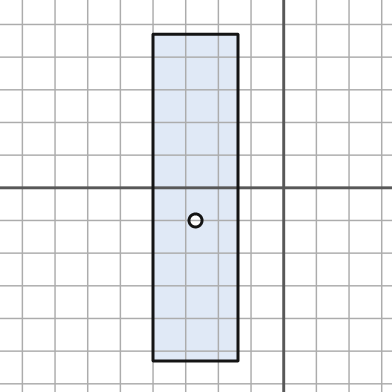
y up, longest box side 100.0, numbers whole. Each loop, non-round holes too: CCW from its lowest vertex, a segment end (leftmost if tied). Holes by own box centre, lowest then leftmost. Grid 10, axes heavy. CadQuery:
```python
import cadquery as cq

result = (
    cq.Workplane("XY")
    .moveTo(-40.0, -53.0)
    .lineTo(-14.0, -53.0)
    .lineTo(-14.0, 47.0)
    .lineTo(-40.0, 47.0)
    .close()
    .moveTo(-27.0, -10.0)
    .circle(2.0)
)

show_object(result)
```